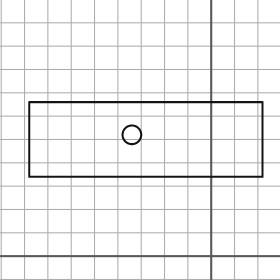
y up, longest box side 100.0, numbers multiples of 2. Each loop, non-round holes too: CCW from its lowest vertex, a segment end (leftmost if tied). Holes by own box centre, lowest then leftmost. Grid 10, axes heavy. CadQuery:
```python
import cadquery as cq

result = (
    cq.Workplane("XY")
    .moveTo(-78.0, 34.0)
    .lineTo(22.0, 34.0)
    .lineTo(22.0, 66.0)
    .lineTo(-78.0, 66.0)
    .close()
    .moveTo(-34.0, 52.0)
    .circle(4.0)
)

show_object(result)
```